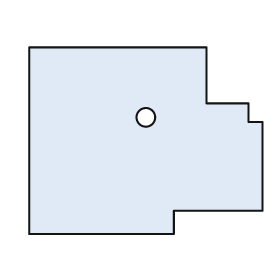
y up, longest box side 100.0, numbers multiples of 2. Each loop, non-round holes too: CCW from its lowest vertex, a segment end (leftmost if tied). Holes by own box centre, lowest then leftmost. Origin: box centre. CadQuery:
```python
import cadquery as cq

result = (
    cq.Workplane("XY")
    .moveTo(-50.0, -40.0)
    .lineTo(12.0, -40.0)
    .lineTo(12.0, -30.0)
    .lineTo(50.0, -30.0)
    .lineTo(50.0, 8.0)
    .lineTo(44.0, 8.0)
    .lineTo(44.0, 16.0)
    .lineTo(26.0, 16.0)
    .lineTo(26.0, 40.0)
    .lineTo(-50.0, 40.0)
    .close()
    .moveTo(0.0, 10.0)
    .circle(4.0)
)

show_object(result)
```